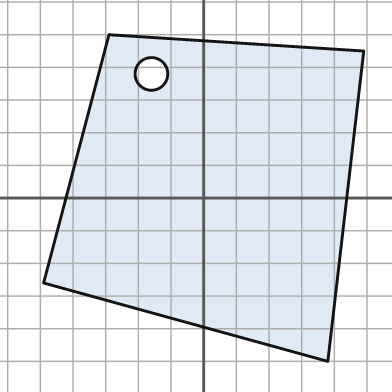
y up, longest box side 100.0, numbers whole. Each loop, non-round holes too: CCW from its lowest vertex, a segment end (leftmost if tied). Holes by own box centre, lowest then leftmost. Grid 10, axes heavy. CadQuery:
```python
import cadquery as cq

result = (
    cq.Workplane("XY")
    .moveTo(38.0, -50.0)
    .lineTo(49.0, 45.0)
    .lineTo(-29.0, 50.0)
    .lineTo(-49.0, -26.0)
    .close()
    .moveTo(-16.0, 38.0)
    .circle(5.0)
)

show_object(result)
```